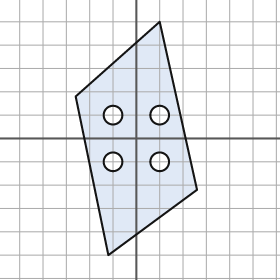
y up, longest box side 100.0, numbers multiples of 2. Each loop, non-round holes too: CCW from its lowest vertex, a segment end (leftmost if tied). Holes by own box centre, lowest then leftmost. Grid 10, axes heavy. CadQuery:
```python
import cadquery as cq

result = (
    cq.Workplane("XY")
    .moveTo(-12.0, -50.0)
    .lineTo(26.0, -22.0)
    .lineTo(10.0, 50.0)
    .lineTo(-26.0, 18.0)
    .close()
    .moveTo(-10.0, -10.0)
    .circle(4.0)
    .moveTo(10.0, -10.0)
    .circle(4.0)
    .moveTo(-10.0, 10.0)
    .circle(4.0)
    .moveTo(10.0, 10.0)
    .circle(4.0)
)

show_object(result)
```